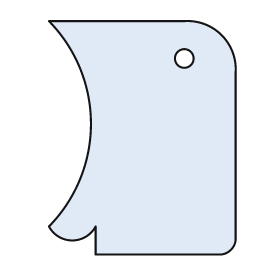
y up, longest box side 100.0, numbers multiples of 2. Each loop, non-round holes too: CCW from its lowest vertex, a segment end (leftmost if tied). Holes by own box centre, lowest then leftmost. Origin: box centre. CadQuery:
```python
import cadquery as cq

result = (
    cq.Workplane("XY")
    .moveTo(-20.0, -50.0)
    .lineTo(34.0, -50.0)
    .threePointArc((38.0, -48.0), (40.0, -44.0))
    .lineTo(40.0, 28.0)
    .threePointArc((34.0, 44.0), (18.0, 50.0))
    .lineTo(-40.0, 50.0)
    .threePointArc((-22.0, 6.0), (-40.0, -38.0))
    .threePointArc((-30.0, -44.0), (-20.0, -38.0))
    .close()
    .moveTo(18.0, 34.0)
    .circle(4.0)
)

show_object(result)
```